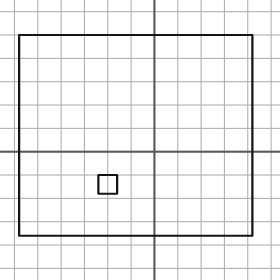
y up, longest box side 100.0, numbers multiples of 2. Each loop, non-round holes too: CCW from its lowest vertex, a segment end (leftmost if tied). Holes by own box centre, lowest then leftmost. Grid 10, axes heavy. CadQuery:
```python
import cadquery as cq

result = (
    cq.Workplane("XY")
    .moveTo(-58.0, -36.0)
    .lineTo(42.0, -36.0)
    .lineTo(42.0, 50.0)
    .lineTo(-58.0, 50.0)
    .close()
    .moveTo(-24.0, -18.0)
    .lineTo(-16.0, -18.0)
    .lineTo(-16.0, -10.0)
    .lineTo(-24.0, -10.0)
    .close()
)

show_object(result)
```